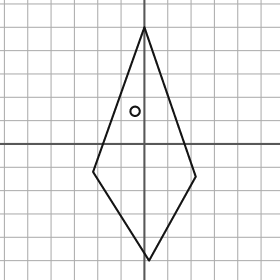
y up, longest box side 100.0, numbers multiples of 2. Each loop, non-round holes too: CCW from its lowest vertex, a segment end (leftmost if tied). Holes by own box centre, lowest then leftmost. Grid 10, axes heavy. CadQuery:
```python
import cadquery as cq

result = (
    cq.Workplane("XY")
    .moveTo(2.0, -50.0)
    .lineTo(22.0, -14.0)
    .lineTo(0.0, 50.0)
    .lineTo(-22.0, -12.0)
    .close()
    .moveTo(-4.0, 14.0)
    .circle(2.0)
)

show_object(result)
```